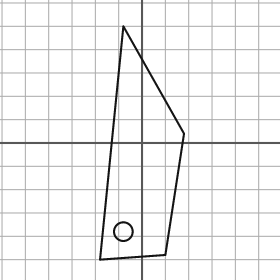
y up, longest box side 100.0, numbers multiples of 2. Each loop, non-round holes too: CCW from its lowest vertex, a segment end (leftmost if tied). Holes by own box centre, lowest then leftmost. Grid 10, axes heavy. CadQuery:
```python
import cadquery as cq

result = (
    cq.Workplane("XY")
    .moveTo(-18.0, -50.0)
    .lineTo(10.0, -48.0)
    .lineTo(18.0, 4.0)
    .lineTo(-8.0, 50.0)
    .close()
    .moveTo(-8.0, -38.0)
    .circle(4.0)
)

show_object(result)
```